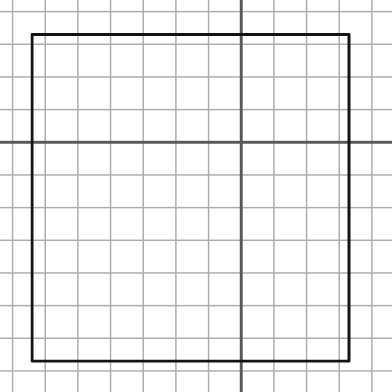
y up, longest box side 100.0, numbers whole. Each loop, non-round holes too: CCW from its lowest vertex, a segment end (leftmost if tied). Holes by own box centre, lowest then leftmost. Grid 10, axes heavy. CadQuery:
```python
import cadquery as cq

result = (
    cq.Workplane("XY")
    .moveTo(-64.0, -67.0)
    .lineTo(33.0, -67.0)
    .lineTo(33.0, 33.0)
    .lineTo(-64.0, 33.0)
    .close()
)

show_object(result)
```